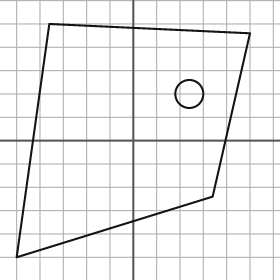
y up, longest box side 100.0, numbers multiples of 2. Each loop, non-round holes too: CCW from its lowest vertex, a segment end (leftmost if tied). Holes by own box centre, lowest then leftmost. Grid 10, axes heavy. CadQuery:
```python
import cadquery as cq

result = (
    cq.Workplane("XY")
    .moveTo(-50.0, -50.0)
    .lineTo(34.0, -24.0)
    .lineTo(50.0, 46.0)
    .lineTo(-36.0, 50.0)
    .close()
    .moveTo(24.0, 20.0)
    .circle(6.0)
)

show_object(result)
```